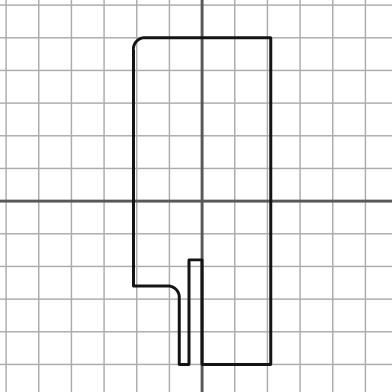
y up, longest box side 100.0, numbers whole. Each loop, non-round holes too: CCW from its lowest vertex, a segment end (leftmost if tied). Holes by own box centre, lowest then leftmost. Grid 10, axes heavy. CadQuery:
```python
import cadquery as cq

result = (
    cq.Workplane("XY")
    .moveTo(-7.0, -50.0)
    .lineTo(-4.0, -50.0)
    .lineTo(-4.0, -18.0)
    .lineTo(0.0, -18.0)
    .lineTo(0.0, -50.0)
    .lineTo(21.0, -50.0)
    .lineTo(21.0, 50.0)
    .lineTo(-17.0, 50.0)
    .threePointArc((-20.0, 49.0), (-21.0, 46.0))
    .lineTo(-21.0, -26.0)
    .lineTo(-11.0, -26.0)
    .threePointArc((-8.0, -27.0), (-7.0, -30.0))
    .close()
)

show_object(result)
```